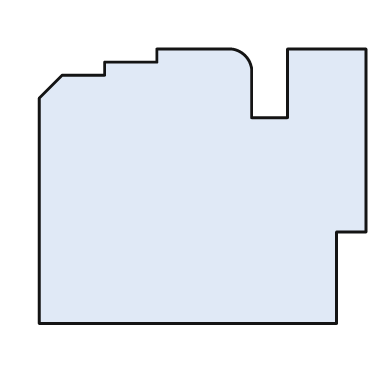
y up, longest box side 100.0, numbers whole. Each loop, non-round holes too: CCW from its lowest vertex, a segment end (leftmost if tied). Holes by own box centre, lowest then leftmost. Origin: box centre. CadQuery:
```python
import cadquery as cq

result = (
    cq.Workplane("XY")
    .moveTo(-50.0, -42.0)
    .lineTo(41.0, -42.0)
    .lineTo(41.0, -14.0)
    .lineTo(50.0, -14.0)
    .lineTo(50.0, 42.0)
    .lineTo(26.0, 42.0)
    .lineTo(26.0, 21.0)
    .lineTo(15.0, 21.0)
    .lineTo(15.0, 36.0)
    .threePointArc((13.0, 40.0), (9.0, 42.0))
    .lineTo(-14.0, 42.0)
    .lineTo(-14.0, 38.0)
    .lineTo(-30.0, 38.0)
    .lineTo(-30.0, 34.0)
    .lineTo(-43.0, 34.0)
    .lineTo(-50.0, 27.0)
    .close()
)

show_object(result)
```